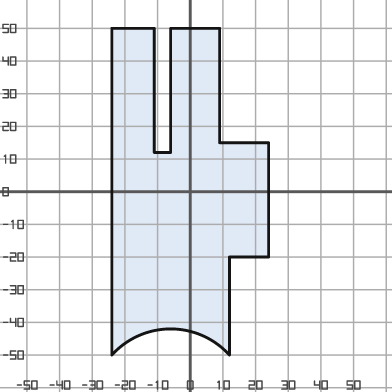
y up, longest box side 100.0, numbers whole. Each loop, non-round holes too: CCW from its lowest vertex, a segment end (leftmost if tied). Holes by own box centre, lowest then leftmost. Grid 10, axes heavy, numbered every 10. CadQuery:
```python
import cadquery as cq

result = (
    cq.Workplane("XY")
    .moveTo(-24.0, -50.0)
    .threePointArc((-6.0, -42.0), (12.0, -50.0))
    .lineTo(12.0, -20.0)
    .lineTo(24.0, -20.0)
    .lineTo(24.0, 15.0)
    .lineTo(9.0, 15.0)
    .lineTo(9.0, 50.0)
    .lineTo(-6.0, 50.0)
    .lineTo(-6.0, 12.0)
    .lineTo(-11.0, 12.0)
    .lineTo(-11.0, 50.0)
    .lineTo(-24.0, 50.0)
    .close()
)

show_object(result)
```